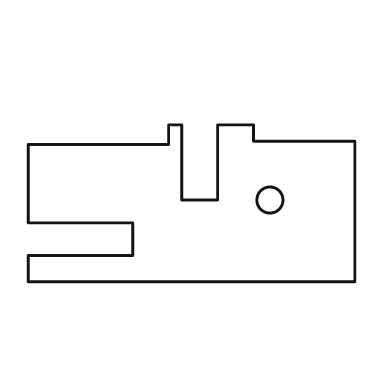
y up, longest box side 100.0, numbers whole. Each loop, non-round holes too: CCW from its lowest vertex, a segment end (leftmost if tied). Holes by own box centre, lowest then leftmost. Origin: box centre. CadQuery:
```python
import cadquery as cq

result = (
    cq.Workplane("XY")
    .moveTo(-50.0, -24.0)
    .lineTo(50.0, -24.0)
    .lineTo(50.0, 19.0)
    .lineTo(19.0, 19.0)
    .lineTo(19.0, 24.0)
    .lineTo(8.0, 24.0)
    .lineTo(8.0, 1.0)
    .lineTo(-3.0, 1.0)
    .lineTo(-3.0, 24.0)
    .lineTo(-7.0, 24.0)
    .lineTo(-7.0, 18.0)
    .lineTo(-50.0, 18.0)
    .lineTo(-50.0, -6.0)
    .lineTo(-18.0, -6.0)
    .lineTo(-18.0, -16.0)
    .lineTo(-50.0, -16.0)
    .close()
    .moveTo(24.0, 1.0)
    .circle(4.0)
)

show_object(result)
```